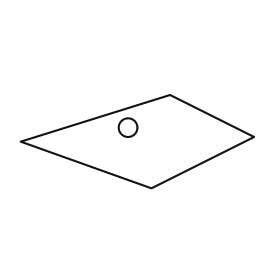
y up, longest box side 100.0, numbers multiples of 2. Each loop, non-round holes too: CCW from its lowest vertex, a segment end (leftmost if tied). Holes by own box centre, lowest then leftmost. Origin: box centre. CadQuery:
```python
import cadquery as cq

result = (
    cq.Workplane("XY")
    .moveTo(6.0, -20.0)
    .lineTo(50.0, 2.0)
    .lineTo(14.0, 20.0)
    .lineTo(-50.0, 0.0)
    .close()
    .moveTo(-4.0, 6.0)
    .circle(4.0)
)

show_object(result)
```